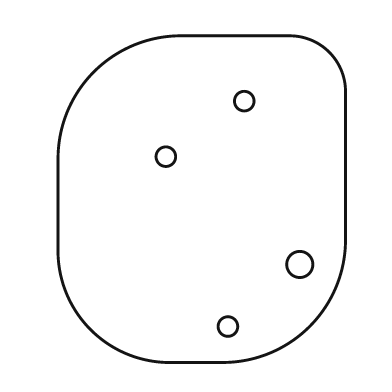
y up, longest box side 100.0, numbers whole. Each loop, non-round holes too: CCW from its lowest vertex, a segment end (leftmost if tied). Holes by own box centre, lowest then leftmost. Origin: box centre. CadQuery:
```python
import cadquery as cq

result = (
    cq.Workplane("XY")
    .moveTo(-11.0, -50.0)
    .lineTo(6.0, -50.0)
    .threePointArc((33.0, -39.0), (44.0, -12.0))
    .lineTo(44.0, 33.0)
    .threePointArc((39.0, 45.0), (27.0, 50.0))
    .lineTo(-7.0, 50.0)
    .threePointArc((-33.0, 39.0), (-44.0, 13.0))
    .lineTo(-44.0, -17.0)
    .threePointArc((-34.0, -40.0), (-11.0, -50.0))
    .close()
    .moveTo(8.0, -39.0)
    .circle(3.0)
    .moveTo(30.0, -20.0)
    .circle(4.0)
    .moveTo(-11.0, 13.0)
    .circle(3.0)
    .moveTo(13.0, 30.0)
    .circle(3.0)
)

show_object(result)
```